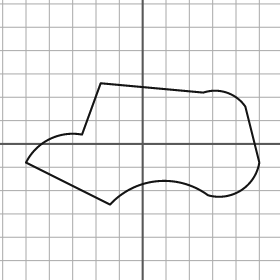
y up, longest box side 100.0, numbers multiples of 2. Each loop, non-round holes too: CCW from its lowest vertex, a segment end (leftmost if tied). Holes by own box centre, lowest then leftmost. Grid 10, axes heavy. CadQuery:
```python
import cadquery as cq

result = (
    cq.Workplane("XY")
    .moveTo(-14.0, -26.0)
    .threePointArc((6.0, -16.0), (28.0, -22.0))
    .threePointArc((42.0, -20.0), (50.0, -8.0))
    .lineTo(44.0, 16.0)
    .threePointArc((36.0, 22.0), (26.0, 22.0))
    .lineTo(-18.0, 26.0)
    .lineTo(-26.0, 4.0)
    .threePointArc((-40.0, 2.0), (-50.0, -8.0))
    .close()
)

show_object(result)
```